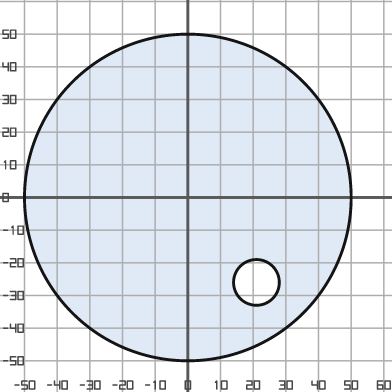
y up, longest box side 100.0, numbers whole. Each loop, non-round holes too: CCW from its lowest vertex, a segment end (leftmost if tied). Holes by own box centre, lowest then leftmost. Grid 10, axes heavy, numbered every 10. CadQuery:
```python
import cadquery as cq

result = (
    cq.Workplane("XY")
    .moveTo(0.0, 0.0)
    .circle(50.0)
    .moveTo(21.0, -26.0)
    .circle(7.0)
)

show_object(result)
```